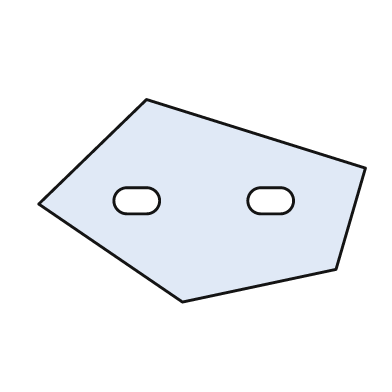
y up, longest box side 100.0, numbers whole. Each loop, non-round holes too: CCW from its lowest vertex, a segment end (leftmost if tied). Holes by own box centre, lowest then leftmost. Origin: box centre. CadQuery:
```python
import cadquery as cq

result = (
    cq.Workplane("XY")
    .moveTo(-6.0, -31.0)
    .lineTo(41.0, -21.0)
    .lineTo(50.0, 10.0)
    .lineTo(-17.0, 31.0)
    .lineTo(-50.0, -1.0)
    .close()
    .moveTo(-23.0, -4.0)
    .lineTo(-17.0, -4.0)
    .threePointArc((-13.0, 0.0), (-17.0, 4.0))
    .lineTo(-23.0, 4.0)
    .threePointArc((-27.0, 0.0), (-23.0, -4.0))
    .close()
    .moveTo(18.0, -4.0)
    .lineTo(24.0, -4.0)
    .threePointArc((28.0, 0.0), (24.0, 4.0))
    .lineTo(18.0, 4.0)
    .threePointArc((14.0, 0.0), (18.0, -4.0))
    .close()
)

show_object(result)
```